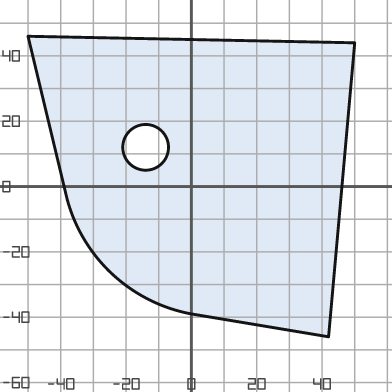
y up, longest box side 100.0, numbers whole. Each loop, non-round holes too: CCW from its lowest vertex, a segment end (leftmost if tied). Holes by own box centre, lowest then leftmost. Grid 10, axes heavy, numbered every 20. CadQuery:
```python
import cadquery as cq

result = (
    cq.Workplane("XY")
    .moveTo(42.0, -46.0)
    .lineTo(50.0, 44.0)
    .lineTo(-50.0, 46.0)
    .lineTo(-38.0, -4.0)
    .threePointArc((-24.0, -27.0), (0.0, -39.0))
    .close()
    .moveTo(-14.0, 12.0)
    .circle(7.0)
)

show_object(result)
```